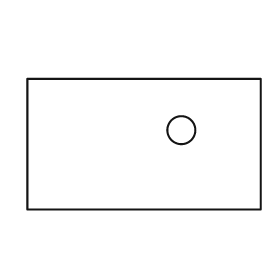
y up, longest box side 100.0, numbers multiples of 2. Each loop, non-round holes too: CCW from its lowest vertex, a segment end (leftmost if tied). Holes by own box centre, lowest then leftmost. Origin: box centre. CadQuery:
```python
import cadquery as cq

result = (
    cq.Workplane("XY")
    .moveTo(-50.0, -28.0)
    .lineTo(50.0, -28.0)
    .lineTo(50.0, 28.0)
    .lineTo(-50.0, 28.0)
    .close()
    .moveTo(16.0, 6.0)
    .circle(6.0)
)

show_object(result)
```